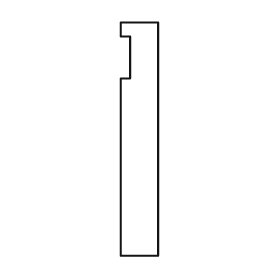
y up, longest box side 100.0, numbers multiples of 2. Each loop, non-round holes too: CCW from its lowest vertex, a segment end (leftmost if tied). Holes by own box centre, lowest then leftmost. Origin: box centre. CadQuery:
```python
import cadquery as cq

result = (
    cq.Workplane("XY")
    .moveTo(-8.0, -50.0)
    .lineTo(8.0, -50.0)
    .lineTo(8.0, 50.0)
    .lineTo(-8.0, 50.0)
    .lineTo(-8.0, 44.0)
    .lineTo(-4.0, 44.0)
    .lineTo(-4.0, 26.0)
    .lineTo(-8.0, 26.0)
    .close()
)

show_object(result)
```